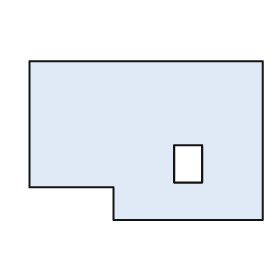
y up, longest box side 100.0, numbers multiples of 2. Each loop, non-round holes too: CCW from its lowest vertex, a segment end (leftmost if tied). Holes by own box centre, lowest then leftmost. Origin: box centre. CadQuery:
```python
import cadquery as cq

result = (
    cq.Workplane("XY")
    .moveTo(-14.0, -34.0)
    .lineTo(50.0, -34.0)
    .lineTo(50.0, 34.0)
    .lineTo(-50.0, 34.0)
    .lineTo(-50.0, -20.0)
    .lineTo(-14.0, -20.0)
    .close()
    .moveTo(12.0, -18.0)
    .lineTo(24.0, -18.0)
    .lineTo(24.0, -2.0)
    .lineTo(12.0, -2.0)
    .close()
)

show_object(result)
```